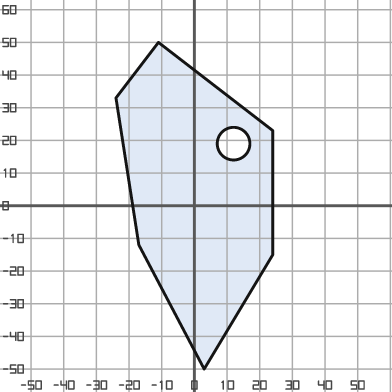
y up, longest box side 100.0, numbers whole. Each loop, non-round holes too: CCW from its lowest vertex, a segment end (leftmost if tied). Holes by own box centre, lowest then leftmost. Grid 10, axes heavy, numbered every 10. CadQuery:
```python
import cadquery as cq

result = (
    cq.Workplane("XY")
    .moveTo(3.0, -50.0)
    .lineTo(24.0, -15.0)
    .lineTo(24.0, 23.0)
    .lineTo(-11.0, 50.0)
    .lineTo(-24.0, 33.0)
    .lineTo(-17.0, -12.0)
    .close()
    .moveTo(12.0, 19.0)
    .circle(5.0)
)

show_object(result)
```